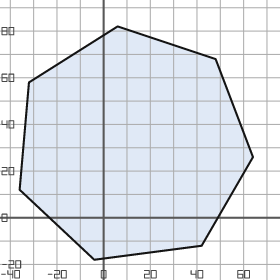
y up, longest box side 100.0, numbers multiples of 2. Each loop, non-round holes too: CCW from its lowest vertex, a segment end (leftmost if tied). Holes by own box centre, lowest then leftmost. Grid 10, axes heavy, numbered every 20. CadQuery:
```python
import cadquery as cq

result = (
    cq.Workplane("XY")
    .moveTo(-4.0, -18.0)
    .lineTo(42.0, -12.0)
    .lineTo(64.0, 26.0)
    .lineTo(48.0, 68.0)
    .lineTo(6.0, 82.0)
    .lineTo(-32.0, 58.0)
    .lineTo(-36.0, 12.0)
    .close()
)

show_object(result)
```